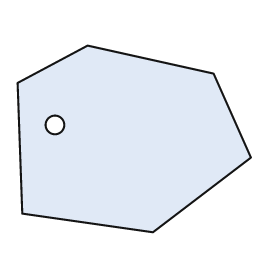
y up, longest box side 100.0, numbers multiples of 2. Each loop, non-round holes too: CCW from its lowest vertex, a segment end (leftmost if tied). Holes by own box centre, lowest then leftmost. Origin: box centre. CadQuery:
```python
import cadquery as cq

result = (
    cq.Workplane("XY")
    .moveTo(8.0, -40.0)
    .lineTo(50.0, -8.0)
    .lineTo(34.0, 28.0)
    .lineTo(-20.0, 40.0)
    .lineTo(-50.0, 24.0)
    .lineTo(-48.0, -32.0)
    .close()
    .moveTo(-34.0, 6.0)
    .circle(4.0)
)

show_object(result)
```